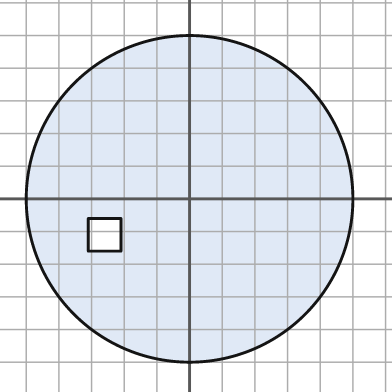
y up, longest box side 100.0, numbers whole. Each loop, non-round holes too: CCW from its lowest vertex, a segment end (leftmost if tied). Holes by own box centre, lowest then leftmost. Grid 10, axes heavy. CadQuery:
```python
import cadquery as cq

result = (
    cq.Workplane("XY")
    .moveTo(0.0, 0.0)
    .circle(50.0)
    .moveTo(-31.0, -16.0)
    .lineTo(-21.0, -16.0)
    .lineTo(-21.0, -6.0)
    .lineTo(-31.0, -6.0)
    .close()
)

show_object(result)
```